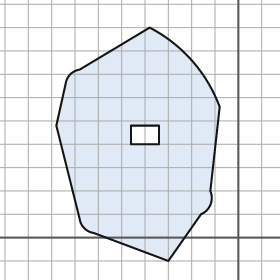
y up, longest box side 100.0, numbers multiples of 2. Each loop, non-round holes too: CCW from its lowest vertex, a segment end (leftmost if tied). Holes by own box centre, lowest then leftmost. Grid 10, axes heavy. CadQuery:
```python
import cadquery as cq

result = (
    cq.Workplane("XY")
    .moveTo(-30.0, -10.0)
    .lineTo(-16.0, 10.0)
    .threePointArc((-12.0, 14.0), (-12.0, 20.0))
    .lineTo(-8.0, 56.0)
    .threePointArc((-20.0, 76.0), (-38.0, 90.0))
    .lineTo(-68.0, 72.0)
    .threePointArc((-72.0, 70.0), (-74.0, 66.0))
    .lineTo(-78.0, 48.0)
    .lineTo(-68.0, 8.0)
    .threePointArc((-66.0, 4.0), (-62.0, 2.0))
    .close()
    .moveTo(-46.0, 40.0)
    .lineTo(-34.0, 40.0)
    .lineTo(-34.0, 48.0)
    .lineTo(-46.0, 48.0)
    .close()
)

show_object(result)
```